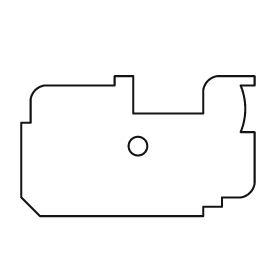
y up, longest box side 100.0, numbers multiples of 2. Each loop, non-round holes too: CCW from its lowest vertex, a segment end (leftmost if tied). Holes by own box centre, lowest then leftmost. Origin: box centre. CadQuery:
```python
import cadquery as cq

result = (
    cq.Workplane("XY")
    .moveTo(-42.0, -30.0)
    .lineTo(28.0, -30.0)
    .lineTo(28.0, -26.0)
    .lineTo(36.0, -26.0)
    .lineTo(36.0, -22.0)
    .lineTo(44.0, -22.0)
    .threePointArc((48.0, -20.0), (50.0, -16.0))
    .lineTo(50.0, 6.0)
    .lineTo(44.0, 6.0)
    .threePointArc((46.0, 16.0), (44.0, 26.0))
    .lineTo(50.0, 26.0)
    .lineTo(50.0, 30.0)
    .lineTo(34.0, 30.0)
    .threePointArc((30.0, 28.0), (28.0, 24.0))
    .lineTo(28.0, 14.0)
    .lineTo(-2.0, 14.0)
    .lineTo(-2.0, 30.0)
    .lineTo(-10.0, 30.0)
    .lineTo(-10.0, 26.0)
    .lineTo(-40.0, 26.0)
    .threePointArc((-44.0, 24.0), (-46.0, 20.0))
    .lineTo(-46.0, 10.0)
    .lineTo(-50.0, 10.0)
    .lineTo(-50.0, -22.0)
    .close()
    .moveTo(0.0, 0.0)
    .circle(4.0)
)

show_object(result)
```